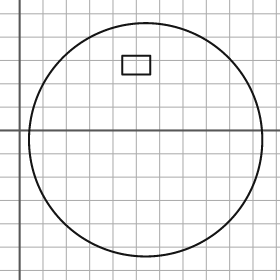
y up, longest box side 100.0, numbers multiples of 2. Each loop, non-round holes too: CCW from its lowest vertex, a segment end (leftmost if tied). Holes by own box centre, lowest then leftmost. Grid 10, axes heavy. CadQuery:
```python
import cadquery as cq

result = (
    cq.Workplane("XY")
    .moveTo(54.0, -4.0)
    .circle(50.0)
    .moveTo(44.0, 24.0)
    .lineTo(56.0, 24.0)
    .lineTo(56.0, 32.0)
    .lineTo(44.0, 32.0)
    .close()
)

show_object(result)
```